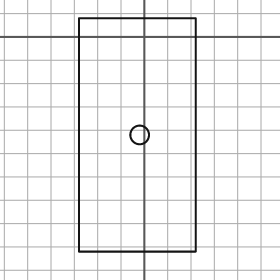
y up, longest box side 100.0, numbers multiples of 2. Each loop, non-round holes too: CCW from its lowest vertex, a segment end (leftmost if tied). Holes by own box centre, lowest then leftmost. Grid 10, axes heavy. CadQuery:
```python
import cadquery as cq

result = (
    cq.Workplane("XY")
    .moveTo(-28.0, -92.0)
    .lineTo(22.0, -92.0)
    .lineTo(22.0, 8.0)
    .lineTo(-28.0, 8.0)
    .close()
    .moveTo(-2.0, -42.0)
    .circle(4.0)
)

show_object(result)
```